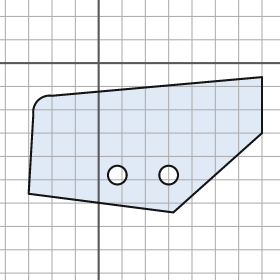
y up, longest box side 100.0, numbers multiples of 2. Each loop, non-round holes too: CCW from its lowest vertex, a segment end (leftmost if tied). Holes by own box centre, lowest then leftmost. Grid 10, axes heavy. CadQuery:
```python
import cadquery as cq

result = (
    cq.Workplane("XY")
    .moveTo(32.0, -64.0)
    .lineTo(70.0, -30.0)
    .lineTo(70.0, -6.0)
    .lineTo(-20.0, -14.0)
    .threePointArc((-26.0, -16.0), (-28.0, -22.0))
    .lineTo(-30.0, -56.0)
    .close()
    .moveTo(8.0, -48.0)
    .circle(4.0)
    .moveTo(30.0, -48.0)
    .circle(4.0)
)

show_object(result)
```